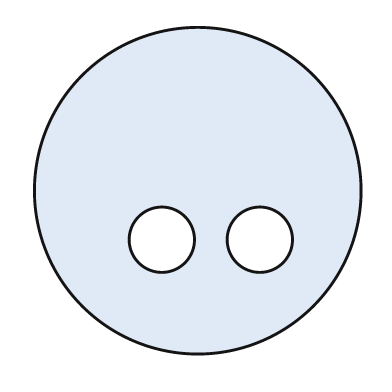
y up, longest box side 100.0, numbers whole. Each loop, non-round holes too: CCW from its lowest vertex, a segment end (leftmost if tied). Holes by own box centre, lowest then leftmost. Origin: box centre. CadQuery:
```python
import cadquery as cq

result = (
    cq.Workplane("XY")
    .moveTo(0.0, 0.0)
    .circle(50.0)
    .moveTo(-11.0, -15.0)
    .circle(10.0)
    .moveTo(19.0, -15.0)
    .circle(10.0)
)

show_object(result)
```